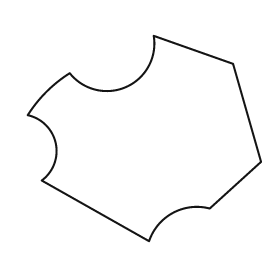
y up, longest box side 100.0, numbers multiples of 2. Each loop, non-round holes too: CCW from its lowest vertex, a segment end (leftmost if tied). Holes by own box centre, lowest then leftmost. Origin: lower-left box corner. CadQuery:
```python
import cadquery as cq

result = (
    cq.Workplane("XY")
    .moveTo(52.0, 0.0)
    .threePointArc((62.0, 12.0), (78.0, 14.0))
    .lineTo(100.0, 34.0)
    .lineTo(88.0, 76.0)
    .lineTo(54.0, 88.0)
    .threePointArc((42.0, 66.0), (18.0, 72.0))
    .threePointArc((8.0, 64.0), (0.0, 54.0))
    .threePointArc((12.0, 42.0), (6.0, 26.0))
    .close()
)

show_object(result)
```